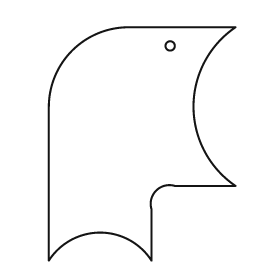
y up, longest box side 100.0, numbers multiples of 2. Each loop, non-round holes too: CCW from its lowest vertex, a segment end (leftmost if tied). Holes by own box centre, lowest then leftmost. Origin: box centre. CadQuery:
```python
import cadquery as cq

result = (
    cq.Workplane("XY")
    .moveTo(-40.0, -50.0)
    .threePointArc((-18.0, -38.0), (4.0, -50.0))
    .lineTo(4.0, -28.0)
    .threePointArc((6.0, -20.0), (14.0, -18.0))
    .lineTo(40.0, -18.0)
    .threePointArc((22.0, 16.0), (40.0, 50.0))
    .lineTo(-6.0, 50.0)
    .threePointArc((-30.0, 40.0), (-40.0, 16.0))
    .close()
    .moveTo(12.0, 42.0)
    .circle(2.0)
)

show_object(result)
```